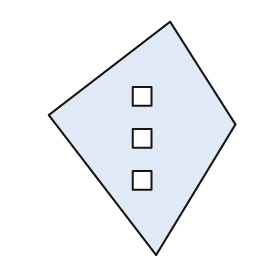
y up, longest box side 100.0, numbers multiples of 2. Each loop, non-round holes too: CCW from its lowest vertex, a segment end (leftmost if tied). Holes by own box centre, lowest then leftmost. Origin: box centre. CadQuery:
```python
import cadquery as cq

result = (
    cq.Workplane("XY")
    .moveTo(6.0, -50.0)
    .lineTo(40.0, 6.0)
    .lineTo(12.0, 50.0)
    .lineTo(-40.0, 10.0)
    .close()
    .moveTo(-4.0, -22.0)
    .lineTo(4.0, -22.0)
    .lineTo(4.0, -14.0)
    .lineTo(-4.0, -14.0)
    .close()
    .moveTo(-4.0, -4.0)
    .lineTo(4.0, -4.0)
    .lineTo(4.0, 4.0)
    .lineTo(-4.0, 4.0)
    .close()
    .moveTo(-4.0, 14.0)
    .lineTo(4.0, 14.0)
    .lineTo(4.0, 22.0)
    .lineTo(-4.0, 22.0)
    .close()
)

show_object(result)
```